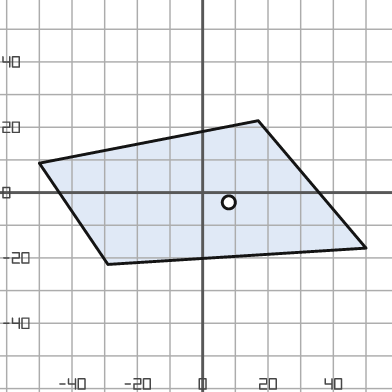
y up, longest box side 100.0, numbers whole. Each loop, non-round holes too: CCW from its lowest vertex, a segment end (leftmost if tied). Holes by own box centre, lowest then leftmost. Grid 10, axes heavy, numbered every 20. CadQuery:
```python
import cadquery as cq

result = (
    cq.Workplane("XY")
    .moveTo(-29.0, -22.0)
    .lineTo(50.0, -17.0)
    .lineTo(17.0, 22.0)
    .lineTo(-50.0, 9.0)
    .close()
    .moveTo(8.0, -3.0)
    .circle(2.0)
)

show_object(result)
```